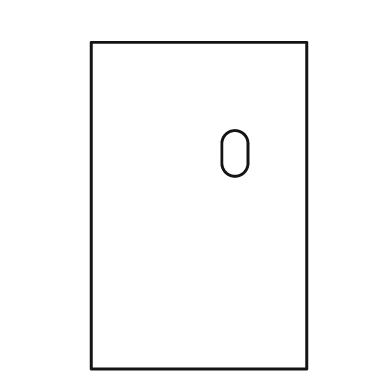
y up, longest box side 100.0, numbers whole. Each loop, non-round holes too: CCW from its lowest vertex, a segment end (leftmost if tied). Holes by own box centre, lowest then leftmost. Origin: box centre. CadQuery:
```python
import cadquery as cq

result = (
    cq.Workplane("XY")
    .moveTo(-33.0, -50.0)
    .lineTo(33.0, -50.0)
    .lineTo(33.0, 50.0)
    .lineTo(-33.0, 50.0)
    .close()
    .moveTo(7.0, 13.0)
    .threePointArc((11.0, 9.0), (15.0, 13.0))
    .lineTo(15.0, 19.0)
    .threePointArc((11.0, 23.0), (7.0, 19.0))
    .close()
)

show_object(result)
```